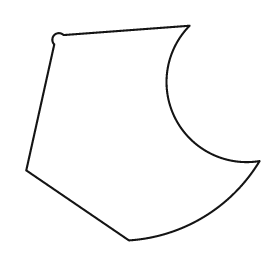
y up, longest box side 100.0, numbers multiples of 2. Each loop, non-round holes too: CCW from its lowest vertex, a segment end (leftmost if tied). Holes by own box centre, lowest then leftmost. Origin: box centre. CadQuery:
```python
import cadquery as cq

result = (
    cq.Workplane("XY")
    .moveTo(-6.0, -46.0)
    .threePointArc((26.0, -36.0), (50.0, -12.0))
    .threePointArc((14.0, 6.0), (20.0, 46.0))
    .lineTo(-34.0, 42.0)
    .threePointArc((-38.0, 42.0), (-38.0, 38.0))
    .lineTo(-50.0, -16.0)
    .close()
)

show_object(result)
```